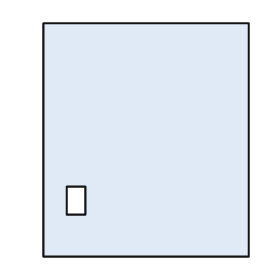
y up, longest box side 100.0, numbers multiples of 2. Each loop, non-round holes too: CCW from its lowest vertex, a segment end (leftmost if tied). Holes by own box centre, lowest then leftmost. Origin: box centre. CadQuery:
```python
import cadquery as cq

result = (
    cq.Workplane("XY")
    .moveTo(-44.0, -50.0)
    .lineTo(44.0, -50.0)
    .lineTo(44.0, 50.0)
    .lineTo(-44.0, 50.0)
    .close()
    .moveTo(-34.0, -32.0)
    .lineTo(-26.0, -32.0)
    .lineTo(-26.0, -20.0)
    .lineTo(-34.0, -20.0)
    .close()
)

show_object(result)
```